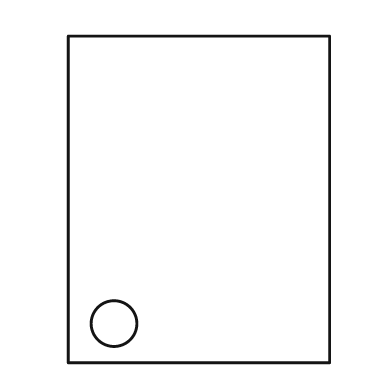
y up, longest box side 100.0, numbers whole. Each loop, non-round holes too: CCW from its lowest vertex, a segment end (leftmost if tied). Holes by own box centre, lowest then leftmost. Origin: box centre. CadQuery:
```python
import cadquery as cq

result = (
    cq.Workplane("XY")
    .moveTo(-40.0, -50.0)
    .lineTo(40.0, -50.0)
    .lineTo(40.0, 50.0)
    .lineTo(-40.0, 50.0)
    .close()
    .moveTo(-26.0, -38.0)
    .circle(7.0)
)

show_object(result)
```